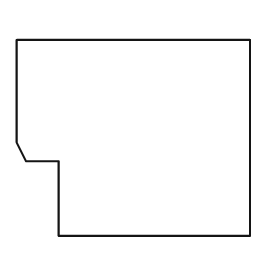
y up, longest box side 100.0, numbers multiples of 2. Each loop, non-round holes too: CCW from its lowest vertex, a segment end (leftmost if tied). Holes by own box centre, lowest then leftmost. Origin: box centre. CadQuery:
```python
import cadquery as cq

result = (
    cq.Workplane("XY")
    .moveTo(-32.0, -42.0)
    .lineTo(50.0, -42.0)
    .lineTo(50.0, 42.0)
    .lineTo(-50.0, 42.0)
    .lineTo(-50.0, -2.0)
    .lineTo(-46.0, -10.0)
    .lineTo(-32.0, -10.0)
    .close()
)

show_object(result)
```